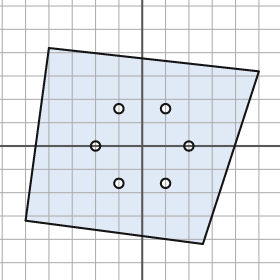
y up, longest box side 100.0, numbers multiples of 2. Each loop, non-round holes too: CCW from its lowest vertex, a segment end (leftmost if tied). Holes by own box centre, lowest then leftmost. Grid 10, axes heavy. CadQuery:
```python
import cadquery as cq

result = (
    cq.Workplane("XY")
    .moveTo(26.0, -42.0)
    .lineTo(50.0, 32.0)
    .lineTo(-40.0, 42.0)
    .lineTo(-50.0, -32.0)
    .close()
    .moveTo(-10.0, -16.0)
    .circle(2.0)
    .moveTo(10.0, -16.0)
    .circle(2.0)
    .moveTo(-20.0, 0.0)
    .circle(2.0)
    .moveTo(20.0, 0.0)
    .circle(2.0)
    .moveTo(-10.0, 16.0)
    .circle(2.0)
    .moveTo(10.0, 16.0)
    .circle(2.0)
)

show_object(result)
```